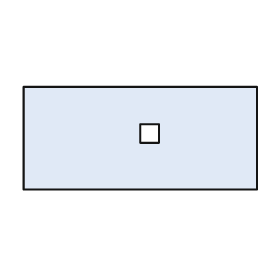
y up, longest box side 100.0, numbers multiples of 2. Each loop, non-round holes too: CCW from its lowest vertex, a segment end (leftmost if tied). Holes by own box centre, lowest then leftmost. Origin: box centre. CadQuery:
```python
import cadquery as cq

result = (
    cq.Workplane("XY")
    .moveTo(-50.0, -22.0)
    .lineTo(50.0, -22.0)
    .lineTo(50.0, 22.0)
    .lineTo(-50.0, 22.0)
    .close()
    .moveTo(0.0, -2.0)
    .lineTo(8.0, -2.0)
    .lineTo(8.0, 6.0)
    .lineTo(0.0, 6.0)
    .close()
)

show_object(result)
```